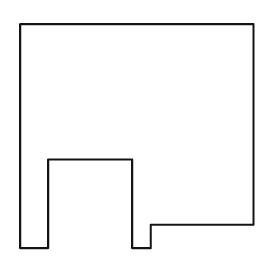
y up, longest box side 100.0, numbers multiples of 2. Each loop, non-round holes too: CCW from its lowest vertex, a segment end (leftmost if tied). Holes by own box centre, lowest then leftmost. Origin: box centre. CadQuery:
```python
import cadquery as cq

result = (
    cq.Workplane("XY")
    .moveTo(-50.0, -48.0)
    .lineTo(-38.0, -48.0)
    .lineTo(-38.0, -10.0)
    .lineTo(-2.0, -10.0)
    .lineTo(-2.0, -48.0)
    .lineTo(6.0, -48.0)
    .lineTo(6.0, -38.0)
    .lineTo(50.0, -38.0)
    .lineTo(50.0, 48.0)
    .lineTo(-50.0, 48.0)
    .close()
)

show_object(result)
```